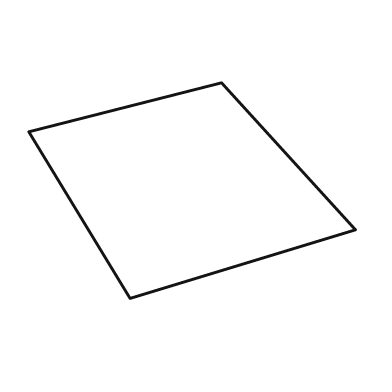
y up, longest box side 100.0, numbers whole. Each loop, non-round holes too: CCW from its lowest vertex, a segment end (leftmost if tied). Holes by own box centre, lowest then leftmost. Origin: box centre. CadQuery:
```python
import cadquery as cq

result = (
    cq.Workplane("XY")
    .moveTo(-19.0, -33.0)
    .lineTo(50.0, -12.0)
    .lineTo(9.0, 33.0)
    .lineTo(-50.0, 18.0)
    .close()
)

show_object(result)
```